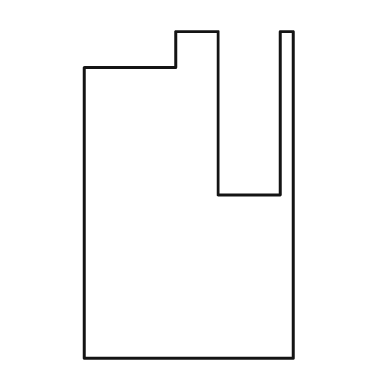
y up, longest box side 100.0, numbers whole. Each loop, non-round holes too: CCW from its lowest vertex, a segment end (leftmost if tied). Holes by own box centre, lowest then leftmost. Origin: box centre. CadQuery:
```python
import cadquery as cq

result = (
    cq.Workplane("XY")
    .moveTo(-32.0, -50.0)
    .lineTo(32.0, -50.0)
    .lineTo(32.0, 50.0)
    .lineTo(28.0, 50.0)
    .lineTo(28.0, 0.0)
    .lineTo(9.0, 0.0)
    .lineTo(9.0, 50.0)
    .lineTo(-4.0, 50.0)
    .lineTo(-4.0, 39.0)
    .lineTo(-32.0, 39.0)
    .close()
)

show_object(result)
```